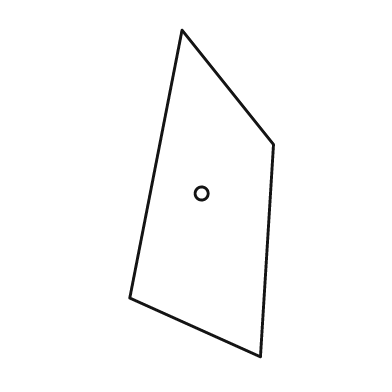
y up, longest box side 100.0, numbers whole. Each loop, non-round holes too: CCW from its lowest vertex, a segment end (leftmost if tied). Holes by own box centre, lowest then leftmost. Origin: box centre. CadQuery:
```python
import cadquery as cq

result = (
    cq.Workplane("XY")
    .moveTo(18.0, -50.0)
    .lineTo(22.0, 15.0)
    .lineTo(-6.0, 50.0)
    .lineTo(-22.0, -32.0)
    .close()
    .moveTo(0.0, 0.0)
    .circle(2.0)
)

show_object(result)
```